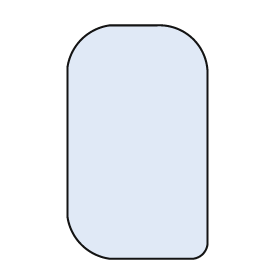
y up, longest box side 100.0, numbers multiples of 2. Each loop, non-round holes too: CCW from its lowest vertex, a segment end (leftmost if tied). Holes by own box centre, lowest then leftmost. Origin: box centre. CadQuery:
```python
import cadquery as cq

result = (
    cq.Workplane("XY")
    .moveTo(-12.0, -50.0)
    .lineTo(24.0, -50.0)
    .threePointArc((28.0, -48.0), (30.0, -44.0))
    .lineTo(30.0, 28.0)
    .threePointArc((24.0, 44.0), (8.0, 50.0))
    .lineTo(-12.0, 50.0)
    .threePointArc((-24.0, 44.0), (-30.0, 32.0))
    .lineTo(-30.0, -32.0)
    .threePointArc((-24.0, -44.0), (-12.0, -50.0))
    .close()
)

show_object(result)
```